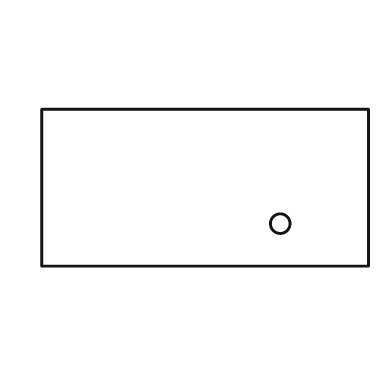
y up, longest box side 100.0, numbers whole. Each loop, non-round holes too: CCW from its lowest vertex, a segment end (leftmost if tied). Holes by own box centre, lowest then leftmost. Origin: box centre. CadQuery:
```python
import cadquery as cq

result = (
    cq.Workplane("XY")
    .moveTo(-50.0, -24.0)
    .lineTo(50.0, -24.0)
    .lineTo(50.0, 24.0)
    .lineTo(-50.0, 24.0)
    .close()
    .moveTo(23.0, -11.0)
    .circle(3.0)
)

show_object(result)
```